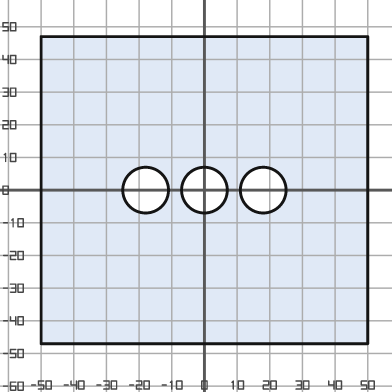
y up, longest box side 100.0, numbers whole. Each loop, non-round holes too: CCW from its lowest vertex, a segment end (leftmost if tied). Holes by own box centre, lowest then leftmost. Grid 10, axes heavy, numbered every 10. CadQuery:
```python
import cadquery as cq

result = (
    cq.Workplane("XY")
    .moveTo(-50.0, -47.0)
    .lineTo(50.0, -47.0)
    .lineTo(50.0, 47.0)
    .lineTo(-50.0, 47.0)
    .close()
    .moveTo(-18.0, 0.0)
    .circle(7.0)
    .moveTo(0.0, 0.0)
    .circle(7.0)
    .moveTo(18.0, 0.0)
    .circle(7.0)
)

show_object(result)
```